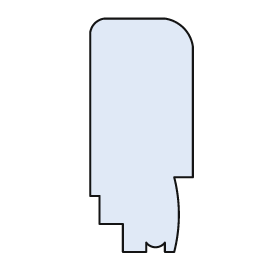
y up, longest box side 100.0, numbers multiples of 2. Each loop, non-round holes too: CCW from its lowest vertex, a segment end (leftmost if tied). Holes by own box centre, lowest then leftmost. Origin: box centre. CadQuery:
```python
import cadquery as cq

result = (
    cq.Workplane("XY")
    .moveTo(-8.0, -50.0)
    .lineTo(2.0, -50.0)
    .lineTo(2.0, -46.0)
    .threePointArc((6.0, -48.0), (10.0, -46.0))
    .lineTo(10.0, -50.0)
    .lineTo(14.0, -50.0)
    .threePointArc((16.0, -34.0), (14.0, -18.0))
    .lineTo(22.0, -18.0)
    .lineTo(22.0, 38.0)
    .threePointArc((18.0, 46.0), (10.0, 50.0))
    .lineTo(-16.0, 50.0)
    .threePointArc((-20.0, 48.0), (-22.0, 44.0))
    .lineTo(-22.0, -26.0)
    .lineTo(-18.0, -26.0)
    .lineTo(-18.0, -38.0)
    .lineTo(-8.0, -38.0)
    .close()
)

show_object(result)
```